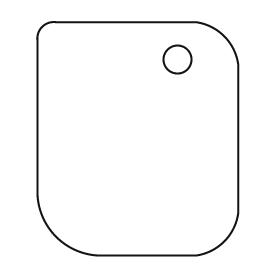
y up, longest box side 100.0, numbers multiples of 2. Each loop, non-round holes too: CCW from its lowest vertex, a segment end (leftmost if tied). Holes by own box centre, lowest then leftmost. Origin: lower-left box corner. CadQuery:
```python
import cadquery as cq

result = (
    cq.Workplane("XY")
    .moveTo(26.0, 0.0)
    .lineTo(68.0, 0.0)
    .threePointArc((80.0, 6.0), (86.0, 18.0))
    .lineTo(86.0, 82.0)
    .threePointArc((80.0, 94.0), (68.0, 100.0))
    .lineTo(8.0, 100.0)
    .threePointArc((2.0, 98.0), (0.0, 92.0))
    .lineTo(0.0, 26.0)
    .threePointArc((8.0, 8.0), (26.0, 0.0))
    .close()
    .moveTo(60.0, 84.0)
    .circle(6.0)
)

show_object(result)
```